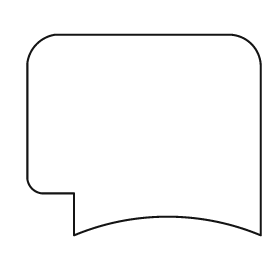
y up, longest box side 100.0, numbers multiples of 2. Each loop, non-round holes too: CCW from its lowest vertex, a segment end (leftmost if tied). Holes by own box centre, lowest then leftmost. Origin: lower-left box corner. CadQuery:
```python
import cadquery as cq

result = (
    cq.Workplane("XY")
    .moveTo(20.0, 0.0)
    .threePointArc((60.0, 8.0), (100.0, 0.0))
    .lineTo(100.0, 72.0)
    .threePointArc((96.0, 82.0), (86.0, 86.0))
    .lineTo(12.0, 86.0)
    .threePointArc((4.0, 82.0), (0.0, 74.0))
    .lineTo(0.0, 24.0)
    .threePointArc((2.0, 20.0), (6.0, 18.0))
    .lineTo(20.0, 18.0)
    .close()
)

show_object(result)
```